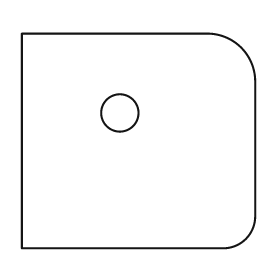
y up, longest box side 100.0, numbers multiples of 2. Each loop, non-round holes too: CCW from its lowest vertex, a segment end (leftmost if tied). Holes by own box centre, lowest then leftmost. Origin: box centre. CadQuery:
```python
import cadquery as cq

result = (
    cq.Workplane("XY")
    .moveTo(-50.0, -46.0)
    .lineTo(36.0, -46.0)
    .threePointArc((46.0, -42.0), (50.0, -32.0))
    .lineTo(50.0, 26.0)
    .threePointArc((44.0, 40.0), (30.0, 46.0))
    .lineTo(-50.0, 46.0)
    .close()
    .moveTo(-8.0, 12.0)
    .circle(8.0)
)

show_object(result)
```